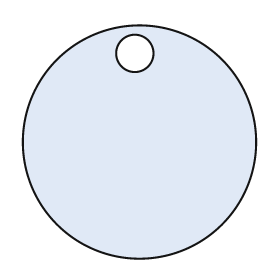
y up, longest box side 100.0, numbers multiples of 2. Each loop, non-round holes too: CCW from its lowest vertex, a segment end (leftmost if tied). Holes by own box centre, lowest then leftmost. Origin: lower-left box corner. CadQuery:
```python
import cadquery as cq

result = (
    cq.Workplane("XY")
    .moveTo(50.0, 50.0)
    .circle(50.0)
    .moveTo(48.0, 88.0)
    .circle(8.0)
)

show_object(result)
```